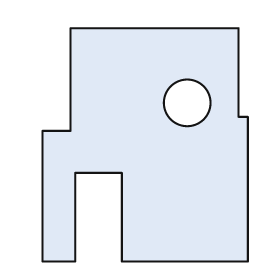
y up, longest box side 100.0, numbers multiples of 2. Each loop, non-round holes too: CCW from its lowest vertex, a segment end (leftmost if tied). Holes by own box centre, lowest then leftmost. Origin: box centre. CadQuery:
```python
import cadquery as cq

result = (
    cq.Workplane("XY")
    .moveTo(-44.0, -50.0)
    .lineTo(-30.0, -50.0)
    .lineTo(-30.0, -12.0)
    .lineTo(-10.0, -12.0)
    .lineTo(-10.0, -50.0)
    .lineTo(44.0, -50.0)
    .lineTo(44.0, 12.0)
    .lineTo(40.0, 12.0)
    .lineTo(40.0, 50.0)
    .lineTo(-32.0, 50.0)
    .lineTo(-32.0, 6.0)
    .lineTo(-44.0, 6.0)
    .close()
    .moveTo(18.0, 18.0)
    .circle(10.0)
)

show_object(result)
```